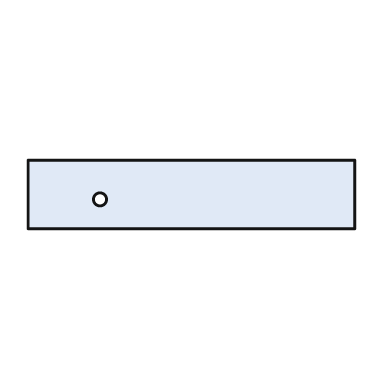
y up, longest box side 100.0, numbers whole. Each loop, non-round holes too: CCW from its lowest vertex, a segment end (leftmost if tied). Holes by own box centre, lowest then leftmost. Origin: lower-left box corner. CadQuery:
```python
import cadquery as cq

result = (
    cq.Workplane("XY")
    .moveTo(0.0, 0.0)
    .lineTo(100.0, 0.0)
    .lineTo(100.0, 21.0)
    .lineTo(0.0, 21.0)
    .close()
    .moveTo(22.0, 9.0)
    .circle(2.0)
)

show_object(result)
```